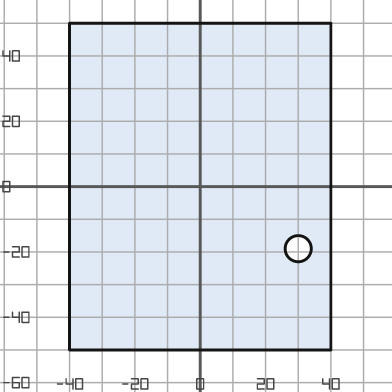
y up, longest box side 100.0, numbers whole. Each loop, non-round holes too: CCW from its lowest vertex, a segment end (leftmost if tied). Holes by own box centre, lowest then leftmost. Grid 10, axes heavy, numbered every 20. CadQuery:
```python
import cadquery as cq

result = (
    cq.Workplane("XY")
    .moveTo(-40.0, -50.0)
    .lineTo(40.0, -50.0)
    .lineTo(40.0, 50.0)
    .lineTo(-40.0, 50.0)
    .close()
    .moveTo(30.0, -19.0)
    .circle(4.0)
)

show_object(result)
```